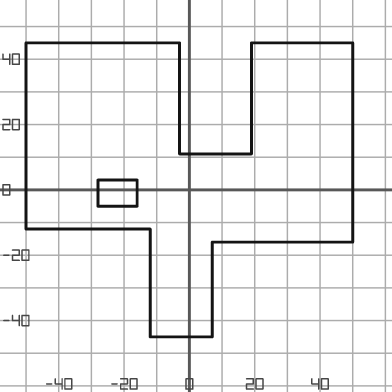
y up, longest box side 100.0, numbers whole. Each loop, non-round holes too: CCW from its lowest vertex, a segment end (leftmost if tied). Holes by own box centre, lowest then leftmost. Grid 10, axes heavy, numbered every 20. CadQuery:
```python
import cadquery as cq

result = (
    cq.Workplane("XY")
    .moveTo(-12.0, -45.0)
    .lineTo(7.0, -45.0)
    .lineTo(7.0, -16.0)
    .lineTo(50.0, -16.0)
    .lineTo(50.0, 45.0)
    .lineTo(19.0, 45.0)
    .lineTo(19.0, 11.0)
    .lineTo(-3.0, 11.0)
    .lineTo(-3.0, 45.0)
    .lineTo(-50.0, 45.0)
    .lineTo(-50.0, -12.0)
    .lineTo(-12.0, -12.0)
    .close()
    .moveTo(-28.0, -5.0)
    .lineTo(-16.0, -5.0)
    .lineTo(-16.0, 3.0)
    .lineTo(-28.0, 3.0)
    .close()
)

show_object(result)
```